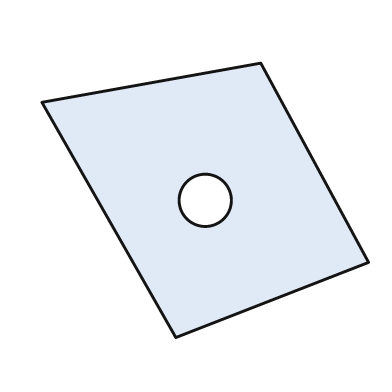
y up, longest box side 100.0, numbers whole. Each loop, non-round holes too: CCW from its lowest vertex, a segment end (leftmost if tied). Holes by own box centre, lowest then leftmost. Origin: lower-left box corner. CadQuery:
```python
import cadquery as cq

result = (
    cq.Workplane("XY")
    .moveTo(41.0, 0.0)
    .lineTo(100.0, 23.0)
    .lineTo(67.0, 84.0)
    .lineTo(0.0, 72.0)
    .close()
    .moveTo(50.0, 42.0)
    .circle(8.0)
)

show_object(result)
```